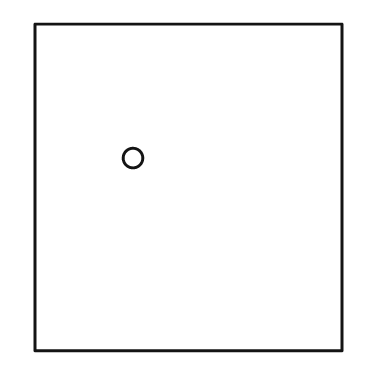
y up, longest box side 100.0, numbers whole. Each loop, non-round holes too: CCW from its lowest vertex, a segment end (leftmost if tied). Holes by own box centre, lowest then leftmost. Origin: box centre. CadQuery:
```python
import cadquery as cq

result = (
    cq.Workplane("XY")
    .moveTo(-47.0, -50.0)
    .lineTo(47.0, -50.0)
    .lineTo(47.0, 50.0)
    .lineTo(-47.0, 50.0)
    .close()
    .moveTo(-17.0, 9.0)
    .circle(3.0)
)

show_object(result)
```